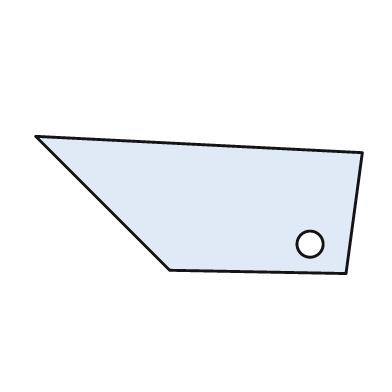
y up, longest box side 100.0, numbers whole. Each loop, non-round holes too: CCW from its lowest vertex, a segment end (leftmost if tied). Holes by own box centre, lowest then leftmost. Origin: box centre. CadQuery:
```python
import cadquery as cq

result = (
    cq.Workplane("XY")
    .moveTo(45.0, -21.0)
    .lineTo(50.0, 16.0)
    .lineTo(-50.0, 21.0)
    .lineTo(-9.0, -20.0)
    .close()
    .moveTo(34.0, -12.0)
    .circle(4.0)
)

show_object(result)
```